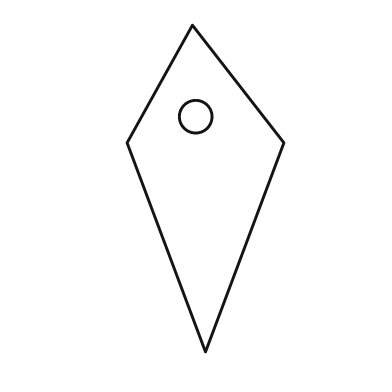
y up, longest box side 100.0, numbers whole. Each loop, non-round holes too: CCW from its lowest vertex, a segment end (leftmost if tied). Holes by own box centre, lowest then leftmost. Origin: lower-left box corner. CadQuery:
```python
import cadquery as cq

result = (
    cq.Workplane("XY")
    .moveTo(24.0, 0.0)
    .lineTo(48.0, 64.0)
    .lineTo(20.0, 100.0)
    .lineTo(0.0, 64.0)
    .close()
    .moveTo(21.0, 72.0)
    .circle(5.0)
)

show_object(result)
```